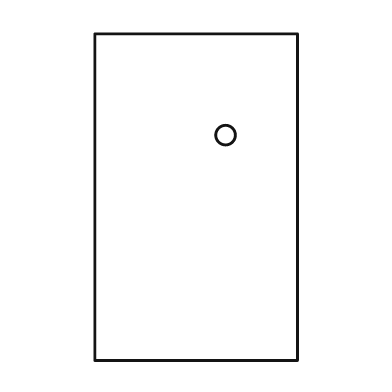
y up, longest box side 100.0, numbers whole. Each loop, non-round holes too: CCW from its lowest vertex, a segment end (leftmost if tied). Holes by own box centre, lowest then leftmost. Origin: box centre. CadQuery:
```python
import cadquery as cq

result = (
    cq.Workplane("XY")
    .moveTo(-31.0, -50.0)
    .lineTo(31.0, -50.0)
    .lineTo(31.0, 50.0)
    .lineTo(-31.0, 50.0)
    .close()
    .moveTo(9.0, 19.0)
    .circle(3.0)
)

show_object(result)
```